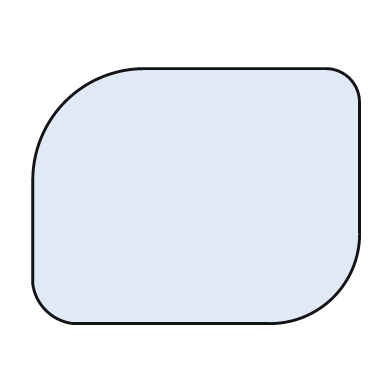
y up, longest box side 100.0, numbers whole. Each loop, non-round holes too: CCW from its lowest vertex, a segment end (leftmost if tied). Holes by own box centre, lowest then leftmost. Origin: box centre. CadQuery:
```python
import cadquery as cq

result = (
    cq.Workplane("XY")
    .moveTo(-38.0, -39.0)
    .lineTo(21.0, -39.0)
    .threePointArc((42.0, -31.0), (50.0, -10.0))
    .lineTo(50.0, 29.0)
    .threePointArc((47.0, 36.0), (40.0, 39.0))
    .lineTo(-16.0, 39.0)
    .threePointArc((-40.0, 29.0), (-50.0, 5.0))
    .lineTo(-50.0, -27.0)
    .threePointArc((-46.0, -35.0), (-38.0, -39.0))
    .close()
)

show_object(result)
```